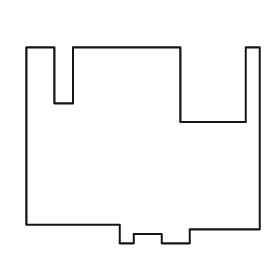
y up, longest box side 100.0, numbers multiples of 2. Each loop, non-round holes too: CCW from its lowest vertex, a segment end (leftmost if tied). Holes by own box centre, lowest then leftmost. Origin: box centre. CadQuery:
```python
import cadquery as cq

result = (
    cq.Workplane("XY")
    .moveTo(-10.0, -42.0)
    .lineTo(-4.0, -42.0)
    .lineTo(-4.0, -38.0)
    .lineTo(8.0, -38.0)
    .lineTo(8.0, -42.0)
    .lineTo(20.0, -42.0)
    .lineTo(20.0, -36.0)
    .lineTo(50.0, -36.0)
    .lineTo(50.0, 42.0)
    .lineTo(44.0, 42.0)
    .lineTo(44.0, 10.0)
    .lineTo(16.0, 10.0)
    .lineTo(16.0, 42.0)
    .lineTo(-30.0, 42.0)
    .lineTo(-30.0, 18.0)
    .lineTo(-38.0, 18.0)
    .lineTo(-38.0, 42.0)
    .lineTo(-50.0, 42.0)
    .lineTo(-50.0, -34.0)
    .lineTo(-10.0, -34.0)
    .close()
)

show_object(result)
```